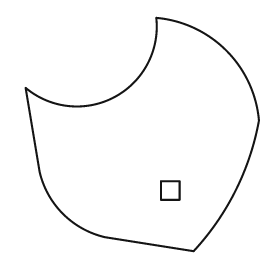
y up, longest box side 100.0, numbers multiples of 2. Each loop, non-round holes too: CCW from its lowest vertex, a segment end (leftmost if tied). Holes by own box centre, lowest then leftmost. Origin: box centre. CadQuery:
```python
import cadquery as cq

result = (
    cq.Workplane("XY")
    .moveTo(22.0, -50.0)
    .threePointArc((40.0, -24.0), (50.0, 6.0))
    .threePointArc((36.0, 36.0), (6.0, 50.0))
    .threePointArc((-12.0, 16.0), (-50.0, 20.0))
    .lineTo(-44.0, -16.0)
    .threePointArc((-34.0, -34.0), (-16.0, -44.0))
    .close()
    .moveTo(8.0, -28.0)
    .lineTo(16.0, -28.0)
    .lineTo(16.0, -20.0)
    .lineTo(8.0, -20.0)
    .close()
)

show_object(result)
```